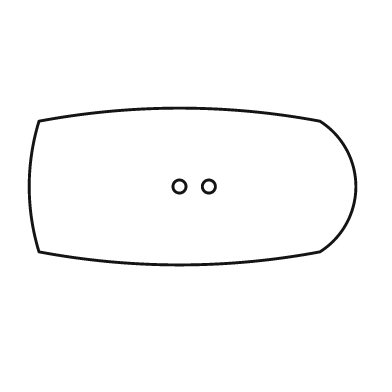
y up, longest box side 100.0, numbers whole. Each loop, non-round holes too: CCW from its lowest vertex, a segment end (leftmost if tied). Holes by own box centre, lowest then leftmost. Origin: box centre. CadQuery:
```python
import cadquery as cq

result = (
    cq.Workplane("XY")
    .moveTo(-47.0, -20.0)
    .threePointArc((-4.0, -24.0), (39.0, -20.0))
    .threePointArc((50.0, 0.0), (39.0, 20.0))
    .threePointArc((-4.0, 24.0), (-47.0, 20.0))
    .threePointArc((-50.0, 0.0), (-47.0, -20.0))
    .close()
    .moveTo(-4.0, 0.0)
    .circle(2.0)
    .moveTo(5.0, 0.0)
    .circle(2.0)
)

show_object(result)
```